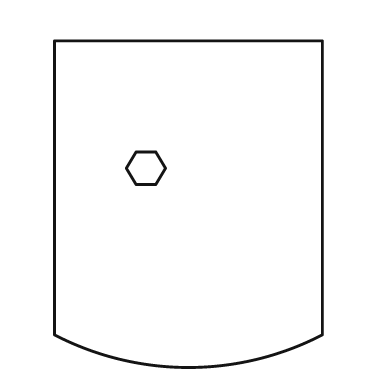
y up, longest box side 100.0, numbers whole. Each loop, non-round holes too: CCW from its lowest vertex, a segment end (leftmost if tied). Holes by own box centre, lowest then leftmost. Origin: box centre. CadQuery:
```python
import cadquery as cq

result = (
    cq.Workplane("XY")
    .moveTo(-41.0, -40.0)
    .threePointArc((0.0, -50.0), (41.0, -40.0))
    .lineTo(41.0, 50.0)
    .lineTo(-41.0, 50.0)
    .close()
    .moveTo(-16.0, 6.0)
    .lineTo(-10.0, 6.0)
    .lineTo(-7.0, 11.0)
    .lineTo(-10.0, 16.0)
    .lineTo(-16.0, 16.0)
    .lineTo(-19.0, 11.0)
    .close()
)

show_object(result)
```